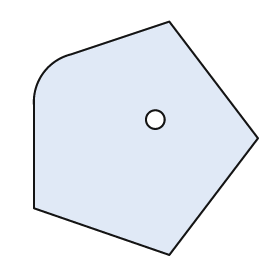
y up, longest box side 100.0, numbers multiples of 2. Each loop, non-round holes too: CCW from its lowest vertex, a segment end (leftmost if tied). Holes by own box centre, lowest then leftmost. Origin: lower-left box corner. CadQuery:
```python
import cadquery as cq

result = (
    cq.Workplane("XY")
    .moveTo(58.0, 0.0)
    .lineTo(96.0, 50.0)
    .lineTo(58.0, 100.0)
    .lineTo(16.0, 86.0)
    .threePointArc((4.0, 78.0), (0.0, 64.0))
    .lineTo(0.0, 20.0)
    .close()
    .moveTo(52.0, 58.0)
    .circle(4.0)
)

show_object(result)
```